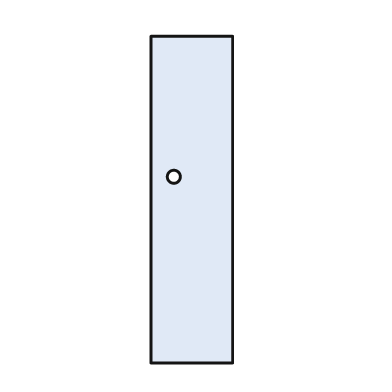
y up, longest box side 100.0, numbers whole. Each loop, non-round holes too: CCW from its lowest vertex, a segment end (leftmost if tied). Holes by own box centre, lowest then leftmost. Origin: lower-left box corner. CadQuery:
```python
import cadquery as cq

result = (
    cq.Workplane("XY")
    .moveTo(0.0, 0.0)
    .lineTo(25.0, 0.0)
    .lineTo(25.0, 100.0)
    .lineTo(0.0, 100.0)
    .close()
    .moveTo(7.0, 57.0)
    .circle(2.0)
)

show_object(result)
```